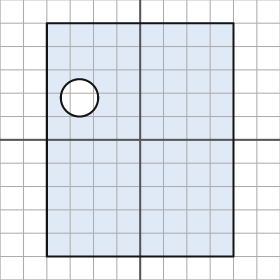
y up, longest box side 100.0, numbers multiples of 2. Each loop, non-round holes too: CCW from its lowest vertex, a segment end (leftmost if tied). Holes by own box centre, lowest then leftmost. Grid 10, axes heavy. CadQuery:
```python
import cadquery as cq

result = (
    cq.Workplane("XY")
    .moveTo(-40.0, -50.0)
    .lineTo(40.0, -50.0)
    .lineTo(40.0, 50.0)
    .lineTo(-40.0, 50.0)
    .close()
    .moveTo(-26.0, 18.0)
    .circle(8.0)
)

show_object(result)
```